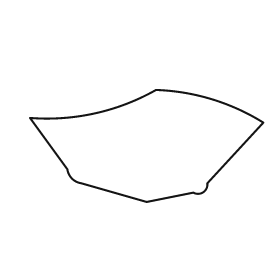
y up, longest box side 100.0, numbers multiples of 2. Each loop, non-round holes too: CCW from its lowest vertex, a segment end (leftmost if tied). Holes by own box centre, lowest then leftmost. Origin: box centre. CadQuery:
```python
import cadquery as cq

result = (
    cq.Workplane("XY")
    .moveTo(0.0, -24.0)
    .lineTo(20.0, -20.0)
    .threePointArc((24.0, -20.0), (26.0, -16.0))
    .lineTo(50.0, 10.0)
    .threePointArc((28.0, 20.0), (4.0, 24.0))
    .threePointArc((-22.0, 14.0), (-50.0, 12.0))
    .lineTo(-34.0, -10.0)
    .threePointArc((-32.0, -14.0), (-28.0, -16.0))
    .close()
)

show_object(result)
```